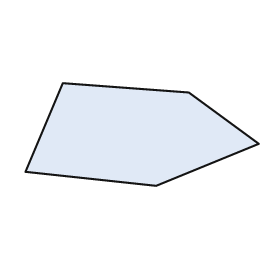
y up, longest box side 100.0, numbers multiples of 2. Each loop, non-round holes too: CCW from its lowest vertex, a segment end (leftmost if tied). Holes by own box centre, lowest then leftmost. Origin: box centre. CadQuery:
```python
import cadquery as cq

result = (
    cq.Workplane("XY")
    .moveTo(6.0, -22.0)
    .lineTo(50.0, -4.0)
    .lineTo(20.0, 18.0)
    .lineTo(-34.0, 22.0)
    .lineTo(-50.0, -16.0)
    .close()
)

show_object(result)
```